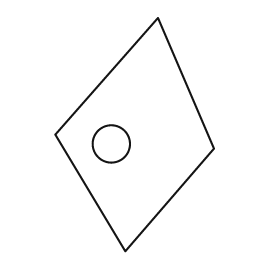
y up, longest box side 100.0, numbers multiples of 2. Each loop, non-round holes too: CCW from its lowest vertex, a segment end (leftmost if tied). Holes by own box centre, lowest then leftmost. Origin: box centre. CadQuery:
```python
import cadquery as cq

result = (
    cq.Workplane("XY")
    .moveTo(-4.0, -50.0)
    .lineTo(34.0, -6.0)
    .lineTo(10.0, 50.0)
    .lineTo(-34.0, 0.0)
    .close()
    .moveTo(-10.0, -4.0)
    .circle(8.0)
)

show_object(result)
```